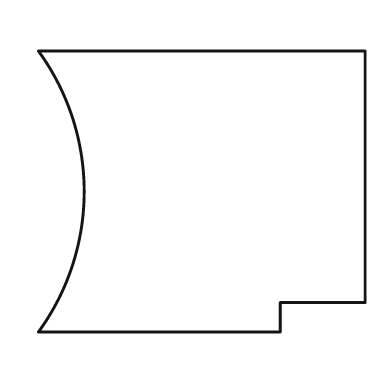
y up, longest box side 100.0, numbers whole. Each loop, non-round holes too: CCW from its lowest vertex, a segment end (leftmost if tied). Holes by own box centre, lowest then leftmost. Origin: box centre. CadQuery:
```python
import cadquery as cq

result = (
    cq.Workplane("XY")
    .moveTo(-50.0, -43.0)
    .lineTo(24.0, -43.0)
    .lineTo(24.0, -34.0)
    .lineTo(50.0, -34.0)
    .lineTo(50.0, 43.0)
    .lineTo(-50.0, 43.0)
    .threePointArc((-36.0, 0.0), (-50.0, -43.0))
    .close()
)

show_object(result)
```